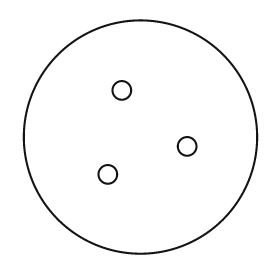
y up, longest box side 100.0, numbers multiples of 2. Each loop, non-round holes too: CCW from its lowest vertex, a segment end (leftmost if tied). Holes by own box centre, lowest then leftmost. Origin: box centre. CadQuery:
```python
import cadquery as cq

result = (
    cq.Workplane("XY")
    .moveTo(0.0, 0.0)
    .circle(50.0)
    .moveTo(-14.0, -16.0)
    .circle(4.0)
    .moveTo(20.0, -4.0)
    .circle(4.0)
    .moveTo(-8.0, 20.0)
    .circle(4.0)
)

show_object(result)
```